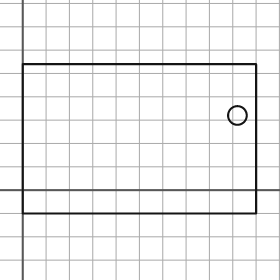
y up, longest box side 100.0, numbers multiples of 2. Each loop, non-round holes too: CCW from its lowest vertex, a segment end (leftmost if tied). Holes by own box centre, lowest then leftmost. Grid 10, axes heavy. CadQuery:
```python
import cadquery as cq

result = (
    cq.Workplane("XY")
    .moveTo(0.0, -10.0)
    .lineTo(100.0, -10.0)
    .lineTo(100.0, 54.0)
    .lineTo(0.0, 54.0)
    .close()
    .moveTo(92.0, 32.0)
    .circle(4.0)
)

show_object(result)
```